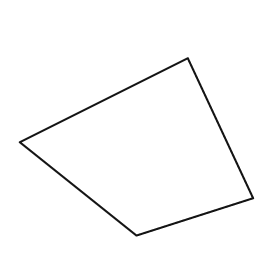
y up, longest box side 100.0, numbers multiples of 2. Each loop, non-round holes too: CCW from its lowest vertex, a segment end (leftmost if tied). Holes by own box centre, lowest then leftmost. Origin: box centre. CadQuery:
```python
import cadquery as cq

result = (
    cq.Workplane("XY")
    .moveTo(0.0, -38.0)
    .lineTo(50.0, -22.0)
    .lineTo(22.0, 38.0)
    .lineTo(-50.0, 2.0)
    .close()
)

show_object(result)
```